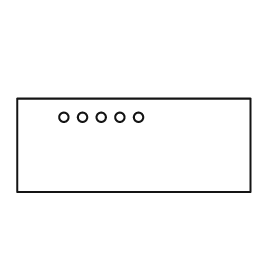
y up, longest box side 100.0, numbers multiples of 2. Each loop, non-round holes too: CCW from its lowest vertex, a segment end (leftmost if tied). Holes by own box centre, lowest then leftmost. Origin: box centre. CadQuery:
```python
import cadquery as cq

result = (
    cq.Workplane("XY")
    .moveTo(-50.0, -20.0)
    .lineTo(50.0, -20.0)
    .lineTo(50.0, 20.0)
    .lineTo(-50.0, 20.0)
    .close()
    .moveTo(-30.0, 12.0)
    .circle(2.0)
    .moveTo(-22.0, 12.0)
    .circle(2.0)
    .moveTo(-14.0, 12.0)
    .circle(2.0)
    .moveTo(-6.0, 12.0)
    .circle(2.0)
    .moveTo(2.0, 12.0)
    .circle(2.0)
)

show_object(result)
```